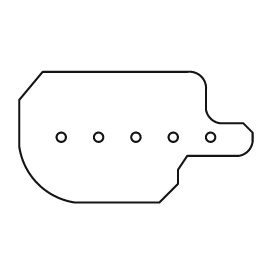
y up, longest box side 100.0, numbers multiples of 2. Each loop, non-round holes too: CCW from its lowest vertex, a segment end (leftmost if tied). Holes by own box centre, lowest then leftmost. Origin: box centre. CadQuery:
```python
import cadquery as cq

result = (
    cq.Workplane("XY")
    .moveTo(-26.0, -28.0)
    .lineTo(10.0, -28.0)
    .lineTo(18.0, -20.0)
    .lineTo(18.0, -14.0)
    .lineTo(22.0, -8.0)
    .lineTo(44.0, -8.0)
    .threePointArc((48.0, -6.0), (50.0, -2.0))
    .lineTo(50.0, 2.0)
    .lineTo(46.0, 6.0)
    .lineTo(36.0, 6.0)
    .threePointArc((32.0, 8.0), (30.0, 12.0))
    .lineTo(30.0, 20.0)
    .threePointArc((28.0, 26.0), (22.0, 28.0))
    .lineTo(-40.0, 28.0)
    .lineTo(-50.0, 16.0)
    .lineTo(-50.0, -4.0)
    .threePointArc((-42.0, -20.0), (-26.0, -28.0))
    .close()
    .moveTo(-32.0, 0.0)
    .circle(2.0)
    .moveTo(-16.0, 0.0)
    .circle(2.0)
    .moveTo(0.0, 0.0)
    .circle(2.0)
    .moveTo(16.0, 0.0)
    .circle(2.0)
    .moveTo(32.0, 0.0)
    .circle(2.0)
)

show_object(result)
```